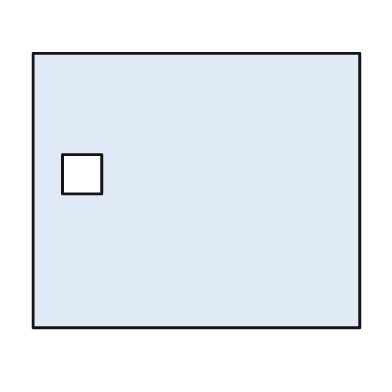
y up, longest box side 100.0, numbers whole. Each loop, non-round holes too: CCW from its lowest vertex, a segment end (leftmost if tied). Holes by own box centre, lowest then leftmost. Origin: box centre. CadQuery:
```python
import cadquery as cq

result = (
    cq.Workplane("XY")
    .moveTo(-50.0, -42.0)
    .lineTo(50.0, -42.0)
    .lineTo(50.0, 42.0)
    .lineTo(-50.0, 42.0)
    .close()
    .moveTo(-41.0, -1.0)
    .lineTo(-29.0, -1.0)
    .lineTo(-29.0, 11.0)
    .lineTo(-41.0, 11.0)
    .close()
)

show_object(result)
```